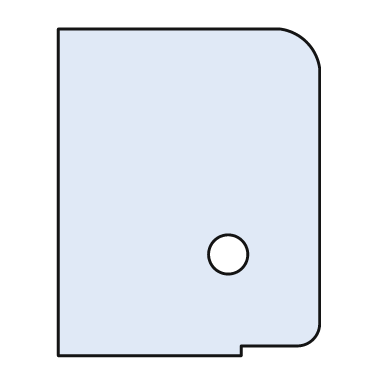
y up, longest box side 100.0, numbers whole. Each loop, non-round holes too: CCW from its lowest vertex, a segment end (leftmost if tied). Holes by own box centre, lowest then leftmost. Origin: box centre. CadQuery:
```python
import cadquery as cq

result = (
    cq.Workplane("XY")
    .moveTo(-40.0, -50.0)
    .lineTo(16.0, -50.0)
    .lineTo(16.0, -47.0)
    .lineTo(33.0, -47.0)
    .threePointArc((38.0, -45.0), (40.0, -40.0))
    .lineTo(40.0, 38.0)
    .threePointArc((36.0, 46.0), (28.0, 50.0))
    .lineTo(-40.0, 50.0)
    .close()
    .moveTo(12.0, -19.0)
    .circle(6.0)
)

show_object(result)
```